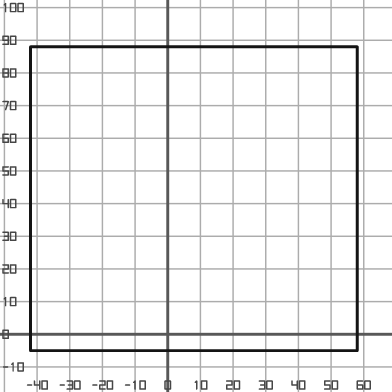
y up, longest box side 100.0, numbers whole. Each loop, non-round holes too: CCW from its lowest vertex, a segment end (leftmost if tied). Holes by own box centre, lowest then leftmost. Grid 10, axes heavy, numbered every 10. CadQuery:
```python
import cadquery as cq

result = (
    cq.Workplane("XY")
    .moveTo(-42.0, -5.0)
    .lineTo(58.0, -5.0)
    .lineTo(58.0, 88.0)
    .lineTo(-42.0, 88.0)
    .close()
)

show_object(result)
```